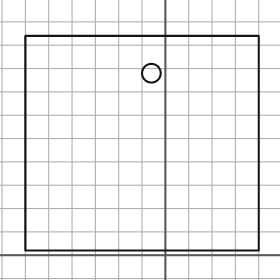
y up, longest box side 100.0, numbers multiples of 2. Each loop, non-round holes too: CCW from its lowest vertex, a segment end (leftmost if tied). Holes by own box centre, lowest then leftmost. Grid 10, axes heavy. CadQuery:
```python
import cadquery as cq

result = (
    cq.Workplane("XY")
    .moveTo(-60.0, 2.0)
    .lineTo(40.0, 2.0)
    .lineTo(40.0, 94.0)
    .lineTo(-60.0, 94.0)
    .close()
    .moveTo(-6.0, 78.0)
    .circle(4.0)
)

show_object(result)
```